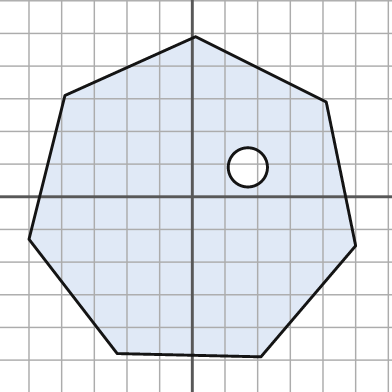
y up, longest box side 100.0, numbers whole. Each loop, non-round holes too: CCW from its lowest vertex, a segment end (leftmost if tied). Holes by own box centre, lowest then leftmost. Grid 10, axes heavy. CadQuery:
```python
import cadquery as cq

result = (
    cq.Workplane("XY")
    .moveTo(21.0, -49.0)
    .lineTo(50.0, -15.0)
    .lineTo(41.0, 29.0)
    .lineTo(1.0, 49.0)
    .lineTo(-39.0, 31.0)
    .lineTo(-50.0, -13.0)
    .lineTo(-23.0, -48.0)
    .close()
    .moveTo(17.0, 9.0)
    .circle(6.0)
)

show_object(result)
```